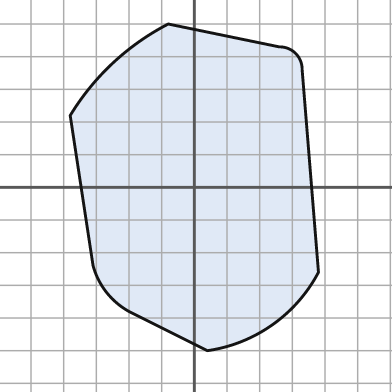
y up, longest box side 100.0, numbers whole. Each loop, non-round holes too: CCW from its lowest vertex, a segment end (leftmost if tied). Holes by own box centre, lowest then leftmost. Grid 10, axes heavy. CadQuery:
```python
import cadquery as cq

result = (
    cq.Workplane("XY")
    .moveTo(4.0, -50.0)
    .threePointArc((24.0, -42.0), (38.0, -26.0))
    .lineTo(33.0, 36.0)
    .threePointArc((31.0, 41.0), (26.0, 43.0))
    .lineTo(-8.0, 50.0)
    .threePointArc((-25.0, 38.0), (-38.0, 22.0))
    .lineTo(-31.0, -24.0)
    .threePointArc((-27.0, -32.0), (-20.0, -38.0))
    .close()
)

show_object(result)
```